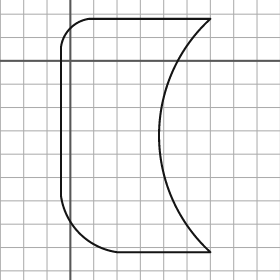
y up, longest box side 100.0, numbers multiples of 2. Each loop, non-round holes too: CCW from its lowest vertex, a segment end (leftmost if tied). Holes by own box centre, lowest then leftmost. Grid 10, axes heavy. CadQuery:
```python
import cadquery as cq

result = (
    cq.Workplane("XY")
    .moveTo(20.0, -82.0)
    .lineTo(60.0, -82.0)
    .threePointArc((38.0, -32.0), (60.0, 18.0))
    .lineTo(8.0, 18.0)
    .threePointArc((0.0, 14.0), (-4.0, 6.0))
    .lineTo(-4.0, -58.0)
    .threePointArc((4.0, -74.0), (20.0, -82.0))
    .close()
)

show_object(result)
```